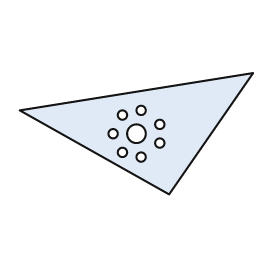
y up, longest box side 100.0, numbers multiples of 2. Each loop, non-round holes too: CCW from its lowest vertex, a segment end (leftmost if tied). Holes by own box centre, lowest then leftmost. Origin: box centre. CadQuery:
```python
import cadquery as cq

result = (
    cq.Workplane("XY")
    .moveTo(14.0, -26.0)
    .lineTo(50.0, 26.0)
    .lineTo(-50.0, 10.0)
    .close()
    .moveTo(2.0, -10.0)
    .circle(2.0)
    .moveTo(-6.0, -8.0)
    .circle(2.0)
    .moveTo(10.0, -4.0)
    .circle(2.0)
    .moveTo(-10.0, 0.0)
    .circle(2.0)
    .moveTo(0.0, 0.0)
    .circle(4.0)
    .moveTo(10.0, 4.0)
    .circle(2.0)
    .moveTo(-6.0, 8.0)
    .circle(2.0)
    .moveTo(2.0, 10.0)
    .circle(2.0)
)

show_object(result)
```